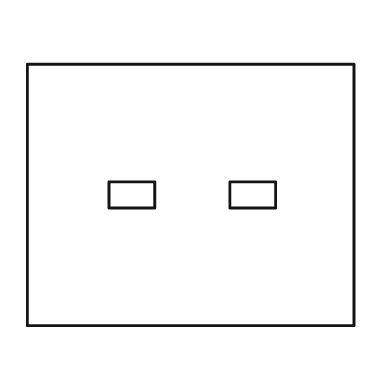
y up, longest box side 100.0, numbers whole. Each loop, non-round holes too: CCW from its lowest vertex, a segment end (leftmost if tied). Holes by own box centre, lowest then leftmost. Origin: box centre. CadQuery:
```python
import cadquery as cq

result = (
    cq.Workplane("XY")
    .moveTo(-50.0, -40.0)
    .lineTo(50.0, -40.0)
    .lineTo(50.0, 40.0)
    .lineTo(-50.0, 40.0)
    .close()
    .moveTo(-25.0, -4.0)
    .lineTo(-11.0, -4.0)
    .lineTo(-11.0, 4.0)
    .lineTo(-25.0, 4.0)
    .close()
    .moveTo(12.0, -4.0)
    .lineTo(26.0, -4.0)
    .lineTo(26.0, 4.0)
    .lineTo(12.0, 4.0)
    .close()
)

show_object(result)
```